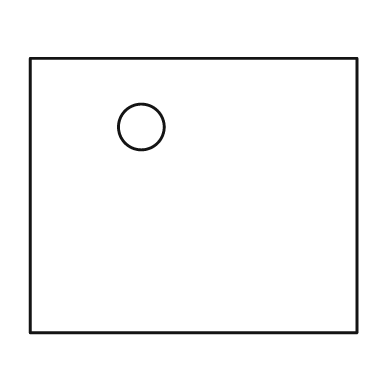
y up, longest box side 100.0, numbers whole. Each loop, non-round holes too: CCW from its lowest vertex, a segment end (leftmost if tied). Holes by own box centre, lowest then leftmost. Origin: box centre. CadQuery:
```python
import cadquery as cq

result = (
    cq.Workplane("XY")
    .moveTo(-50.0, -42.0)
    .lineTo(50.0, -42.0)
    .lineTo(50.0, 42.0)
    .lineTo(-50.0, 42.0)
    .close()
    .moveTo(-16.0, 21.0)
    .circle(7.0)
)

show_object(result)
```